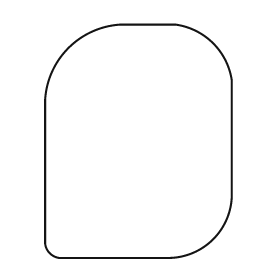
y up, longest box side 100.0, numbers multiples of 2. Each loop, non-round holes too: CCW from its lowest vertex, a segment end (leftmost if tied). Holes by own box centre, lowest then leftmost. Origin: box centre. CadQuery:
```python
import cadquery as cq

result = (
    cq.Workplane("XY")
    .moveTo(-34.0, -50.0)
    .lineTo(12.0, -50.0)
    .threePointArc((32.0, -42.0), (40.0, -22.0))
    .lineTo(40.0, 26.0)
    .threePointArc((32.0, 42.0), (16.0, 50.0))
    .lineTo(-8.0, 50.0)
    .threePointArc((-30.0, 40.0), (-40.0, 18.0))
    .lineTo(-40.0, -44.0)
    .threePointArc((-38.0, -48.0), (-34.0, -50.0))
    .close()
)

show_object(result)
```